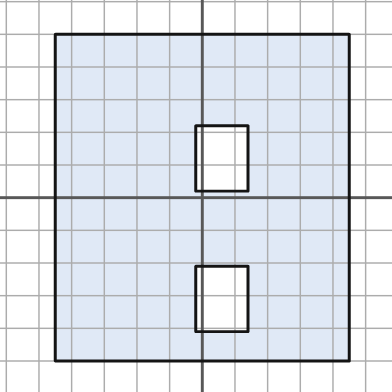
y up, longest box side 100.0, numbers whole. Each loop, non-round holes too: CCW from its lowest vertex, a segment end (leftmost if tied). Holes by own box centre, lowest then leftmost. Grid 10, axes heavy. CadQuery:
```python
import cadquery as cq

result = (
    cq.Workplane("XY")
    .moveTo(-45.0, -50.0)
    .lineTo(45.0, -50.0)
    .lineTo(45.0, 50.0)
    .lineTo(-45.0, 50.0)
    .close()
    .moveTo(-2.0, -41.0)
    .lineTo(14.0, -41.0)
    .lineTo(14.0, -21.0)
    .lineTo(-2.0, -21.0)
    .close()
    .moveTo(-2.0, 2.0)
    .lineTo(14.0, 2.0)
    .lineTo(14.0, 22.0)
    .lineTo(-2.0, 22.0)
    .close()
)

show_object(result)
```